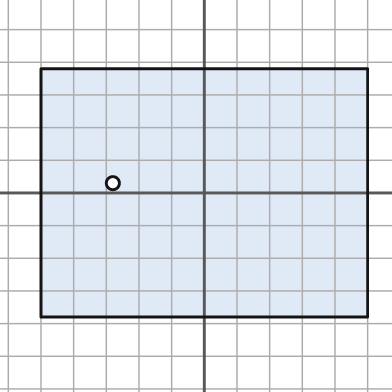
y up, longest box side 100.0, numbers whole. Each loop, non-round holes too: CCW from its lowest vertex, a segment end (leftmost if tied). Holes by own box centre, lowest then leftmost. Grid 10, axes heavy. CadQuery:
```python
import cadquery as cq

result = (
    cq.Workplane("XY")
    .moveTo(-50.0, -38.0)
    .lineTo(50.0, -38.0)
    .lineTo(50.0, 38.0)
    .lineTo(-50.0, 38.0)
    .close()
    .moveTo(-28.0, 3.0)
    .circle(2.0)
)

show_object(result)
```